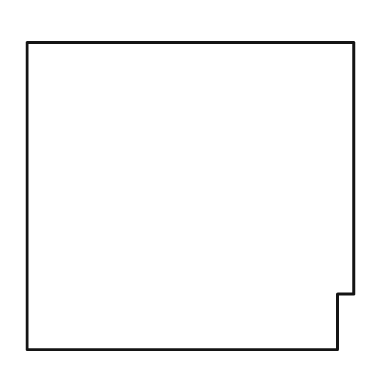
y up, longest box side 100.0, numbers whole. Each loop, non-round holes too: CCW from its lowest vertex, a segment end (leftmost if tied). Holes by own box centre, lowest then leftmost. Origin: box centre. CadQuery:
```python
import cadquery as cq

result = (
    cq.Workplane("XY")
    .moveTo(-50.0, -47.0)
    .lineTo(45.0, -47.0)
    .lineTo(45.0, -30.0)
    .lineTo(50.0, -30.0)
    .lineTo(50.0, 47.0)
    .lineTo(-50.0, 47.0)
    .close()
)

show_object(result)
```